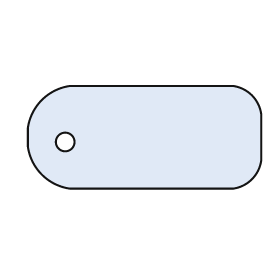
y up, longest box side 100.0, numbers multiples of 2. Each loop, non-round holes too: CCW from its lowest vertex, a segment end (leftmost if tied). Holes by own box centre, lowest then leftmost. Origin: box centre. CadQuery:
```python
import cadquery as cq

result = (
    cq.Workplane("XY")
    .moveTo(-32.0, -22.0)
    .lineTo(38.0, -22.0)
    .threePointArc((46.0, -18.0), (50.0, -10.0))
    .lineTo(50.0, 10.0)
    .threePointArc((46.0, 18.0), (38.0, 22.0))
    .lineTo(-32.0, 22.0)
    .threePointArc((-44.0, 16.0), (-50.0, 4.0))
    .lineTo(-50.0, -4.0)
    .threePointArc((-44.0, -16.0), (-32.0, -22.0))
    .close()
    .moveTo(-34.0, -2.0)
    .circle(4.0)
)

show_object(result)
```